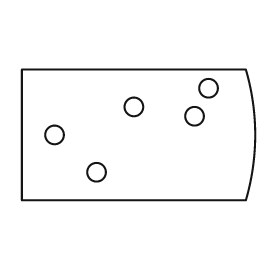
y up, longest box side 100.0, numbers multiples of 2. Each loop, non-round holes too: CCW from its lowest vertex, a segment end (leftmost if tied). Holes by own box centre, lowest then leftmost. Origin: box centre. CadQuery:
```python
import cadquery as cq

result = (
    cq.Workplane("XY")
    .moveTo(-50.0, -28.0)
    .lineTo(46.0, -28.0)
    .threePointArc((50.0, 0.0), (46.0, 28.0))
    .lineTo(-50.0, 28.0)
    .close()
    .moveTo(-18.0, -16.0)
    .circle(4.0)
    .moveTo(-36.0, 0.0)
    .circle(4.0)
    .moveTo(24.0, 8.0)
    .circle(4.0)
    .moveTo(-2.0, 12.0)
    .circle(4.0)
    .moveTo(30.0, 20.0)
    .circle(4.0)
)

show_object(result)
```